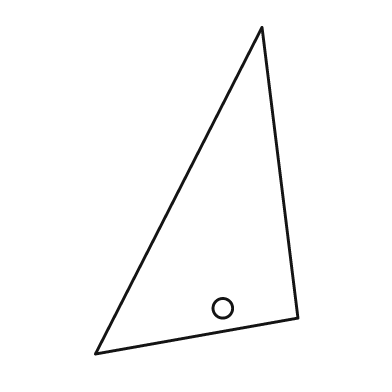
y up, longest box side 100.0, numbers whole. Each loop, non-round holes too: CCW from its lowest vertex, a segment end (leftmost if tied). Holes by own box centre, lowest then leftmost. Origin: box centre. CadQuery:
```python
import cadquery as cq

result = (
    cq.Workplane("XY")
    .moveTo(-31.0, -50.0)
    .lineTo(31.0, -39.0)
    .lineTo(20.0, 50.0)
    .close()
    .moveTo(8.0, -36.0)
    .circle(3.0)
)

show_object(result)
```